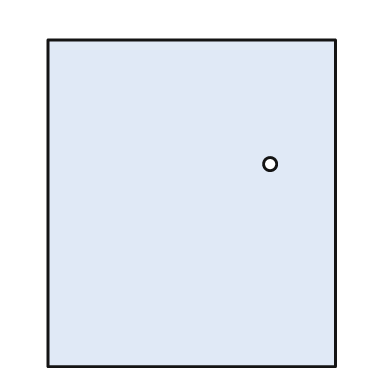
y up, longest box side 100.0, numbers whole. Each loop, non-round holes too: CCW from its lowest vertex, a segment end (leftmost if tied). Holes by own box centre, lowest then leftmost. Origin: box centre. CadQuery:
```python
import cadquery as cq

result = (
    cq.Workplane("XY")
    .moveTo(-44.0, -50.0)
    .lineTo(44.0, -50.0)
    .lineTo(44.0, 50.0)
    .lineTo(-44.0, 50.0)
    .close()
    .moveTo(24.0, 12.0)
    .circle(2.0)
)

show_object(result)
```